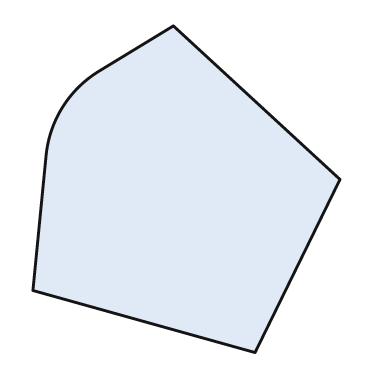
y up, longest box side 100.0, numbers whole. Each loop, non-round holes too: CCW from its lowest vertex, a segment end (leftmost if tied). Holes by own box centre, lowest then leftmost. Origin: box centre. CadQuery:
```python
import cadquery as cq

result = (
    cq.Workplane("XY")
    .moveTo(21.0, -50.0)
    .lineTo(47.0, 3.0)
    .lineTo(-4.0, 50.0)
    .lineTo(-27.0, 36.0)
    .threePointArc((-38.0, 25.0), (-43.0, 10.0))
    .lineTo(-47.0, -31.0)
    .close()
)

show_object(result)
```